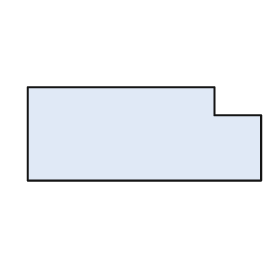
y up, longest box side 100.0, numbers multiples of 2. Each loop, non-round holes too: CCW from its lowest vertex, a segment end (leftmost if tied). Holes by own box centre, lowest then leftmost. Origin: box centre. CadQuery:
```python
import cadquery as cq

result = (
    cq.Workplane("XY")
    .moveTo(-50.0, -20.0)
    .lineTo(50.0, -20.0)
    .lineTo(50.0, 8.0)
    .lineTo(30.0, 8.0)
    .lineTo(30.0, 20.0)
    .lineTo(-50.0, 20.0)
    .close()
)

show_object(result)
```